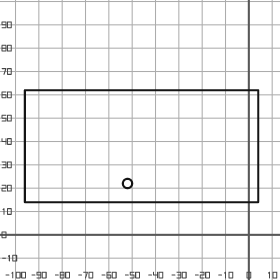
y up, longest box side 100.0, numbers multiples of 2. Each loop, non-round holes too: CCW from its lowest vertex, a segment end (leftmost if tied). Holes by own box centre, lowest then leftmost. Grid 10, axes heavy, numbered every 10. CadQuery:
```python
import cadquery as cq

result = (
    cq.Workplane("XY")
    .moveTo(-96.0, 14.0)
    .lineTo(4.0, 14.0)
    .lineTo(4.0, 62.0)
    .lineTo(-96.0, 62.0)
    .close()
    .moveTo(-52.0, 22.0)
    .circle(2.0)
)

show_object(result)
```